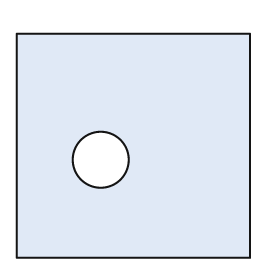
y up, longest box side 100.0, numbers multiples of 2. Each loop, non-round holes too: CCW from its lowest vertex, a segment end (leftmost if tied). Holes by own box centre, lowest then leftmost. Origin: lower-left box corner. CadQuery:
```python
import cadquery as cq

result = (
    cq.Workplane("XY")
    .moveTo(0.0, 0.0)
    .lineTo(100.0, 0.0)
    .lineTo(100.0, 96.0)
    .lineTo(0.0, 96.0)
    .close()
    .moveTo(36.0, 42.0)
    .circle(12.0)
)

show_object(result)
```